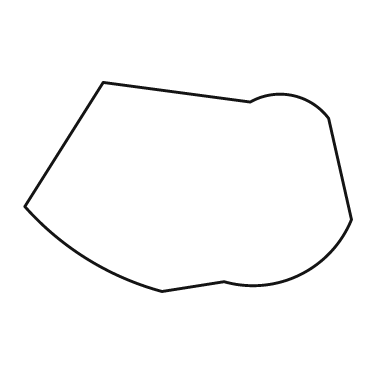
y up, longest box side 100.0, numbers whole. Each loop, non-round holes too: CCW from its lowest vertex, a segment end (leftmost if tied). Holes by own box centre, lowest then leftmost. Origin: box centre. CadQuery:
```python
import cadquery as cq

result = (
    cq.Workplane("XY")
    .moveTo(-8.0, -32.0)
    .lineTo(11.0, -29.0)
    .threePointArc((34.0, -27.0), (50.0, -10.0))
    .lineTo(43.0, 21.0)
    .threePointArc((32.0, 28.0), (19.0, 26.0))
    .lineTo(-26.0, 32.0)
    .lineTo(-50.0, -6.0)
    .threePointArc((-31.0, -22.0), (-8.0, -32.0))
    .close()
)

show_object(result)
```